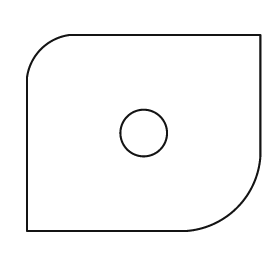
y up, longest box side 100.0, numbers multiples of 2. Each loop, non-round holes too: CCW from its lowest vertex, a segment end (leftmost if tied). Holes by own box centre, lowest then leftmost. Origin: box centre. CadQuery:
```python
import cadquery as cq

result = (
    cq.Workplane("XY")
    .moveTo(-50.0, -42.0)
    .lineTo(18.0, -42.0)
    .threePointArc((40.0, -32.0), (50.0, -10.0))
    .lineTo(50.0, 42.0)
    .lineTo(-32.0, 42.0)
    .threePointArc((-44.0, 36.0), (-50.0, 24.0))
    .close()
    .moveTo(0.0, 0.0)
    .circle(10.0)
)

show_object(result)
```